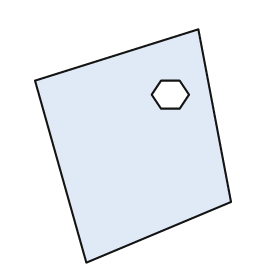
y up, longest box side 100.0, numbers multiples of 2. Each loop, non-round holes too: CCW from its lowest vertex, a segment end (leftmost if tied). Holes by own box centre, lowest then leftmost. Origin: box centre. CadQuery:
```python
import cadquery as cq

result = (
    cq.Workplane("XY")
    .moveTo(-20.0, -50.0)
    .lineTo(42.0, -24.0)
    .lineTo(28.0, 50.0)
    .lineTo(-42.0, 28.0)
    .close()
    .moveTo(12.0, 16.0)
    .lineTo(20.0, 16.0)
    .lineTo(24.0, 22.0)
    .lineTo(20.0, 28.0)
    .lineTo(12.0, 28.0)
    .lineTo(8.0, 22.0)
    .close()
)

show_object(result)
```